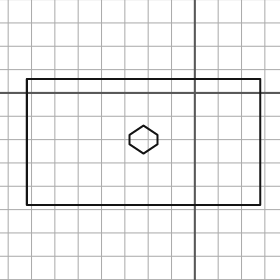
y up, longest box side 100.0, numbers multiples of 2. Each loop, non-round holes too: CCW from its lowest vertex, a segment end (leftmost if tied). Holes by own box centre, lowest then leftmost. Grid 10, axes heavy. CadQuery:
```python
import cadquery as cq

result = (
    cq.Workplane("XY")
    .moveTo(-72.0, -48.0)
    .lineTo(28.0, -48.0)
    .lineTo(28.0, 6.0)
    .lineTo(-72.0, 6.0)
    .close()
    .moveTo(-22.0, -26.0)
    .lineTo(-16.0, -22.0)
    .lineTo(-16.0, -18.0)
    .lineTo(-22.0, -14.0)
    .lineTo(-28.0, -18.0)
    .lineTo(-28.0, -22.0)
    .close()
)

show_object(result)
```